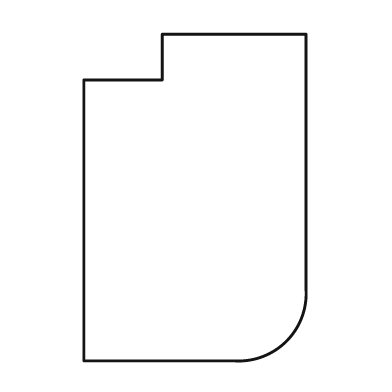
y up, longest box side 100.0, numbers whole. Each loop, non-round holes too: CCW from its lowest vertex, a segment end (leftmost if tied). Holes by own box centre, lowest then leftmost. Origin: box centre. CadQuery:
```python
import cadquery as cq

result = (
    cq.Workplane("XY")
    .moveTo(-34.0, -50.0)
    .lineTo(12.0, -50.0)
    .threePointArc((28.0, -44.0), (34.0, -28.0))
    .lineTo(34.0, 50.0)
    .lineTo(-10.0, 50.0)
    .lineTo(-10.0, 36.0)
    .lineTo(-34.0, 36.0)
    .close()
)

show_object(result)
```